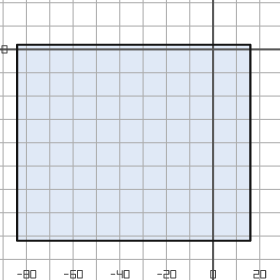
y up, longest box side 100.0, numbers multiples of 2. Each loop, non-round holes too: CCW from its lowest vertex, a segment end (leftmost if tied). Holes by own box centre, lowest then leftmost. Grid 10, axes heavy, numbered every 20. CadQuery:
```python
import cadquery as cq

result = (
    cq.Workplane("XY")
    .moveTo(-84.0, -82.0)
    .lineTo(16.0, -82.0)
    .lineTo(16.0, 2.0)
    .lineTo(-84.0, 2.0)
    .close()
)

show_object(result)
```